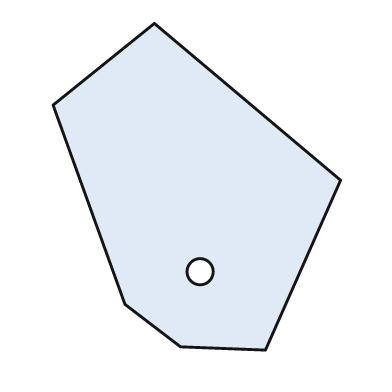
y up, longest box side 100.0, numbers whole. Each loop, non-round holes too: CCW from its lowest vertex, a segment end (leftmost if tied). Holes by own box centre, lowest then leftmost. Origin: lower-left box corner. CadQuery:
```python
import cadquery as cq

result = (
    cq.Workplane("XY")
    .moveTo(65.0, 0.0)
    .lineTo(88.0, 52.0)
    .lineTo(31.0, 100.0)
    .lineTo(0.0, 75.0)
    .lineTo(22.0, 14.0)
    .lineTo(39.0, 1.0)
    .close()
    .moveTo(45.0, 24.0)
    .circle(4.0)
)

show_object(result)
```